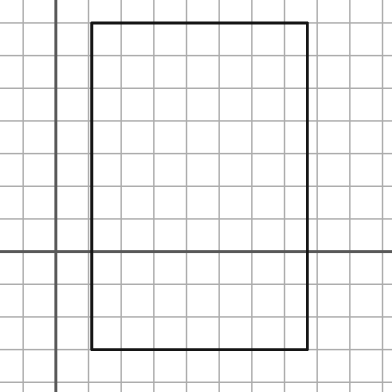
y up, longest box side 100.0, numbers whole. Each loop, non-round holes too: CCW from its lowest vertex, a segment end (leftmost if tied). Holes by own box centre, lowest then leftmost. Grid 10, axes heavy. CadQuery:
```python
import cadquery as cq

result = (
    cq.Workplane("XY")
    .moveTo(11.0, -30.0)
    .lineTo(77.0, -30.0)
    .lineTo(77.0, 70.0)
    .lineTo(11.0, 70.0)
    .close()
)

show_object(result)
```